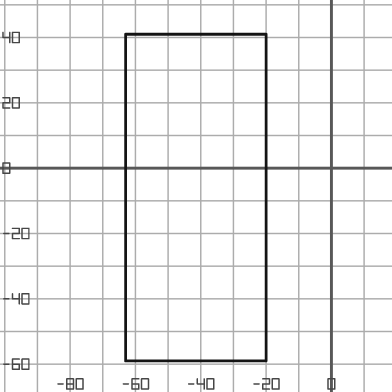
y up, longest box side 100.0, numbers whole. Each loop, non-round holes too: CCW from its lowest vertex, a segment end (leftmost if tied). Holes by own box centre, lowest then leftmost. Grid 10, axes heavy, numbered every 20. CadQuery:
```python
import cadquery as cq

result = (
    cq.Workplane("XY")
    .moveTo(-63.0, -59.0)
    .lineTo(-20.0, -59.0)
    .lineTo(-20.0, 41.0)
    .lineTo(-63.0, 41.0)
    .close()
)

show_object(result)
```